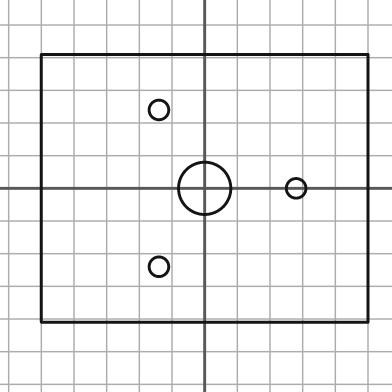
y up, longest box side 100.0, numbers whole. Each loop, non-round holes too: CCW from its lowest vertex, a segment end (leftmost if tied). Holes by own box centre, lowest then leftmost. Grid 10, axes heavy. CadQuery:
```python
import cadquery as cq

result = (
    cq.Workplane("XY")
    .moveTo(-50.0, -41.0)
    .lineTo(50.0, -41.0)
    .lineTo(50.0, 41.0)
    .lineTo(-50.0, 41.0)
    .close()
    .moveTo(-14.0, -24.0)
    .circle(3.0)
    .moveTo(0.0, 0.0)
    .circle(8.0)
    .moveTo(28.0, 0.0)
    .circle(3.0)
    .moveTo(-14.0, 24.0)
    .circle(3.0)
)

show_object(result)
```